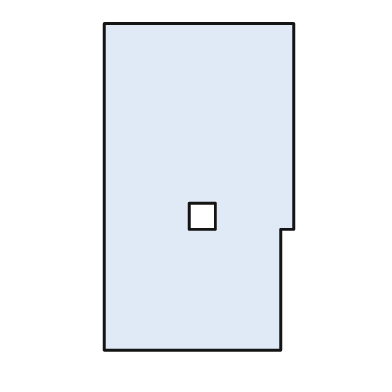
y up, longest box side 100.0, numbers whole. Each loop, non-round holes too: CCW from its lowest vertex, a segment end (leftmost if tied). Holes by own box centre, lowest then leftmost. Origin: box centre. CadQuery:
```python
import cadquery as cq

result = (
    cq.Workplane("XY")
    .moveTo(-29.0, -50.0)
    .lineTo(25.0, -50.0)
    .lineTo(25.0, -13.0)
    .lineTo(29.0, -13.0)
    .lineTo(29.0, 50.0)
    .lineTo(-29.0, 50.0)
    .close()
    .moveTo(-3.0, -13.0)
    .lineTo(5.0, -13.0)
    .lineTo(5.0, -5.0)
    .lineTo(-3.0, -5.0)
    .close()
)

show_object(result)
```